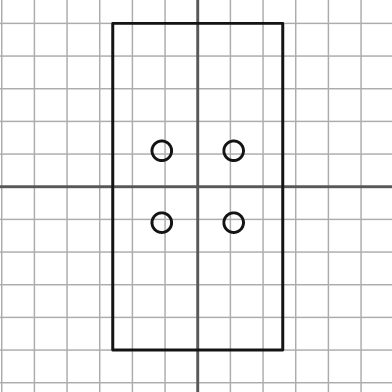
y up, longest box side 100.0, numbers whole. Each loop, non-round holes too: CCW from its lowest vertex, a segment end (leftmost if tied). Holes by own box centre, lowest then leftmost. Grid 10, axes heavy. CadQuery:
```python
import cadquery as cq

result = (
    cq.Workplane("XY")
    .moveTo(-26.0, -50.0)
    .lineTo(26.0, -50.0)
    .lineTo(26.0, 50.0)
    .lineTo(-26.0, 50.0)
    .close()
    .moveTo(-11.0, -11.0)
    .circle(3.0)
    .moveTo(11.0, -11.0)
    .circle(3.0)
    .moveTo(-11.0, 11.0)
    .circle(3.0)
    .moveTo(11.0, 11.0)
    .circle(3.0)
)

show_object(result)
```